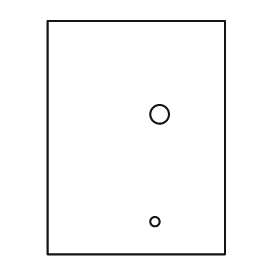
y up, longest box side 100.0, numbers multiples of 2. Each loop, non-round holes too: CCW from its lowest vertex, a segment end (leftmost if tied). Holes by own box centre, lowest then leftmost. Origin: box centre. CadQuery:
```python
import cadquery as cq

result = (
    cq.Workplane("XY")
    .moveTo(-38.0, -50.0)
    .lineTo(38.0, -50.0)
    .lineTo(38.0, 50.0)
    .lineTo(-38.0, 50.0)
    .close()
    .moveTo(8.0, -36.0)
    .circle(2.0)
    .moveTo(10.0, 10.0)
    .circle(4.0)
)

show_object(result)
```